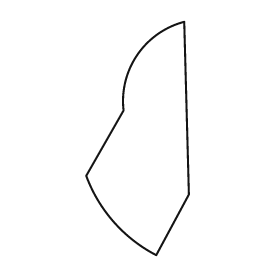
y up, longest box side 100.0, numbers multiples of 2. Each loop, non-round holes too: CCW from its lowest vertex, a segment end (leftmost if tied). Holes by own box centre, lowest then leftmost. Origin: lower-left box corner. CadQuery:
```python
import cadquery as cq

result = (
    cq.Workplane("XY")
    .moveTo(30.0, 0.0)
    .lineTo(44.0, 26.0)
    .lineTo(42.0, 100.0)
    .threePointArc((22.0, 86.0), (16.0, 62.0))
    .lineTo(0.0, 34.0)
    .threePointArc((12.0, 14.0), (30.0, 0.0))
    .close()
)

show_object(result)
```